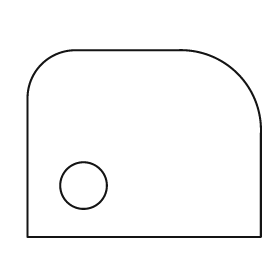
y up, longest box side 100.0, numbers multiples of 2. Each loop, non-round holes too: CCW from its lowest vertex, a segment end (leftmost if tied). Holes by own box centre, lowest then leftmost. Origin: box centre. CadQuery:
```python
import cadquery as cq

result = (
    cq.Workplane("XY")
    .moveTo(-50.0, -40.0)
    .lineTo(50.0, -40.0)
    .lineTo(50.0, 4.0)
    .threePointArc((40.0, 30.0), (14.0, 40.0))
    .lineTo(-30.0, 40.0)
    .threePointArc((-44.0, 34.0), (-50.0, 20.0))
    .close()
    .moveTo(-26.0, -18.0)
    .circle(10.0)
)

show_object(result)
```